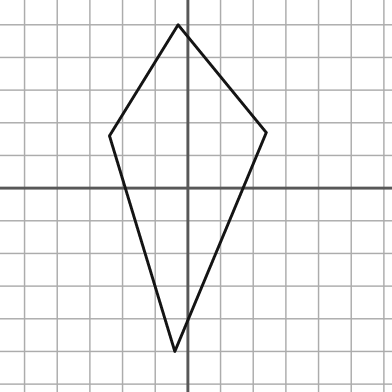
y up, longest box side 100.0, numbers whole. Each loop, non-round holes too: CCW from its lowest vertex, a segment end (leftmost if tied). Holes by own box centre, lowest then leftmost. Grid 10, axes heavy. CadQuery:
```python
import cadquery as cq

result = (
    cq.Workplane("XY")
    .moveTo(-4.0, -50.0)
    .lineTo(24.0, 17.0)
    .lineTo(-3.0, 50.0)
    .lineTo(-24.0, 16.0)
    .close()
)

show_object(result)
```